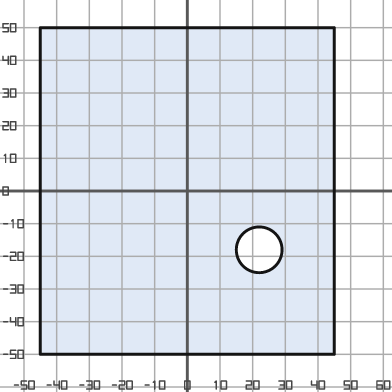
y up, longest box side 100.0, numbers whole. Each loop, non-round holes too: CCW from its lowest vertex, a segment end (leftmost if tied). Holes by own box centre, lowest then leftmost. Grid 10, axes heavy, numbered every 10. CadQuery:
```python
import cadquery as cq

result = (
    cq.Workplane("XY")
    .moveTo(-45.0, -50.0)
    .lineTo(45.0, -50.0)
    .lineTo(45.0, 50.0)
    .lineTo(-45.0, 50.0)
    .close()
    .moveTo(22.0, -18.0)
    .circle(7.0)
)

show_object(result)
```